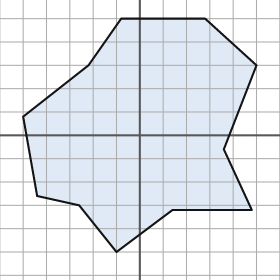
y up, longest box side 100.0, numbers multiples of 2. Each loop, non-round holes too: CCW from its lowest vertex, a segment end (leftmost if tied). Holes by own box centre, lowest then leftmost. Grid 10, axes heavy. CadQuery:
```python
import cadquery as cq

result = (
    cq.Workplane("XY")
    .moveTo(-10.0, -50.0)
    .lineTo(14.0, -32.0)
    .lineTo(48.0, -32.0)
    .lineTo(36.0, -6.0)
    .lineTo(50.0, 30.0)
    .lineTo(28.0, 50.0)
    .lineTo(-8.0, 50.0)
    .lineTo(-22.0, 30.0)
    .lineTo(-50.0, 8.0)
    .lineTo(-44.0, -26.0)
    .lineTo(-26.0, -30.0)
    .close()
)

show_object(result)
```